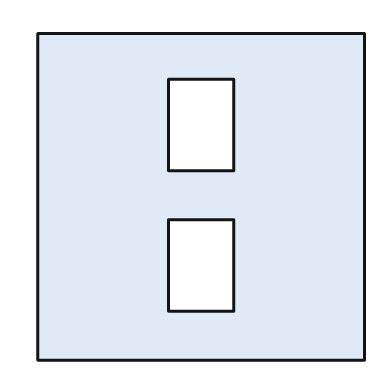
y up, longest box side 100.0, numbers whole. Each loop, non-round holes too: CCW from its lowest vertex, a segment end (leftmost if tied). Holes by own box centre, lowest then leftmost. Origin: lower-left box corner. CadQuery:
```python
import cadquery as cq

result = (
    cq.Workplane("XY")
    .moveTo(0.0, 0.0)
    .lineTo(100.0, 0.0)
    .lineTo(100.0, 100.0)
    .lineTo(0.0, 100.0)
    .close()
    .moveTo(40.0, 15.0)
    .lineTo(60.0, 15.0)
    .lineTo(60.0, 43.0)
    .lineTo(40.0, 43.0)
    .close()
    .moveTo(40.0, 58.0)
    .lineTo(60.0, 58.0)
    .lineTo(60.0, 86.0)
    .lineTo(40.0, 86.0)
    .close()
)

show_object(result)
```